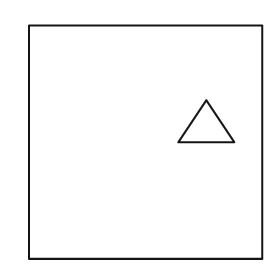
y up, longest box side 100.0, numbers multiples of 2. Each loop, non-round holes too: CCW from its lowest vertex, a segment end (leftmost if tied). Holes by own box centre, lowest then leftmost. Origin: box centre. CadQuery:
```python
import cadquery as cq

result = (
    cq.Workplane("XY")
    .moveTo(-50.0, -50.0)
    .lineTo(50.0, -50.0)
    .lineTo(50.0, 50.0)
    .lineTo(-50.0, 50.0)
    .close()
    .moveTo(14.0, 0.0)
    .lineTo(38.0, 0.0)
    .lineTo(26.0, 18.0)
    .close()
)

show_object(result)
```